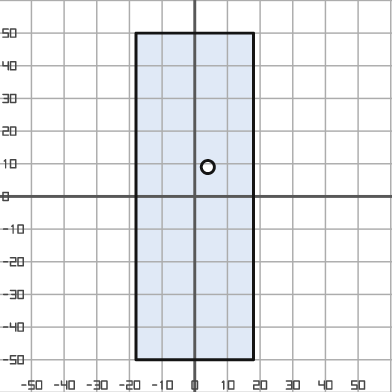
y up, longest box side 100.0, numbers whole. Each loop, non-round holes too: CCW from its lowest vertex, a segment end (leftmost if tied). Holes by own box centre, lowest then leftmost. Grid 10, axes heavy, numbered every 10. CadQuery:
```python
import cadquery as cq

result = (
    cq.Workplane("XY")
    .moveTo(-18.0, -50.0)
    .lineTo(18.0, -50.0)
    .lineTo(18.0, 50.0)
    .lineTo(-18.0, 50.0)
    .close()
    .moveTo(4.0, 9.0)
    .circle(2.0)
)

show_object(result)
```